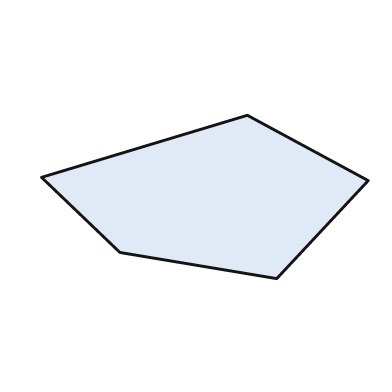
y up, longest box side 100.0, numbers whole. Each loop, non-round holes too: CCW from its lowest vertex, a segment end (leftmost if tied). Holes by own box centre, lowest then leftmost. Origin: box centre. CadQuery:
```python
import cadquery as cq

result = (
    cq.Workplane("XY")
    .moveTo(22.0, -25.0)
    .lineTo(50.0, 5.0)
    .lineTo(13.0, 25.0)
    .lineTo(-50.0, 6.0)
    .lineTo(-26.0, -17.0)
    .close()
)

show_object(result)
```